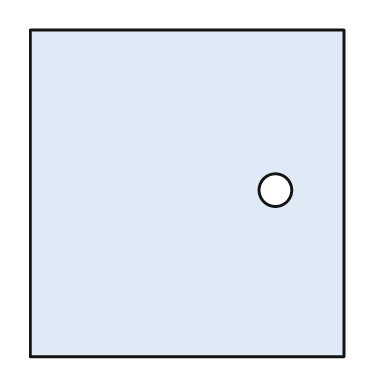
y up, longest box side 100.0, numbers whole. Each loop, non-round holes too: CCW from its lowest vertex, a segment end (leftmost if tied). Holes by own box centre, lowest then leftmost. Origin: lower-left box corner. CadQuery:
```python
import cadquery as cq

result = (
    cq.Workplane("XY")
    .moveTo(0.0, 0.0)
    .lineTo(96.0, 0.0)
    .lineTo(96.0, 100.0)
    .lineTo(0.0, 100.0)
    .close()
    .moveTo(75.0, 51.0)
    .circle(5.0)
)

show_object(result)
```